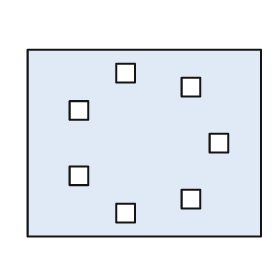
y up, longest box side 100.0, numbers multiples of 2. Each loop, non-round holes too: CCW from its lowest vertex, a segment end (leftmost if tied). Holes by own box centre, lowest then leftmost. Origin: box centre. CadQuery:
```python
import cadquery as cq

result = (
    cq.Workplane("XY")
    .moveTo(-50.0, -40.0)
    .lineTo(50.0, -40.0)
    .lineTo(50.0, 40.0)
    .lineTo(-50.0, 40.0)
    .close()
    .moveTo(-12.0, -34.0)
    .lineTo(-4.0, -34.0)
    .lineTo(-4.0, -26.0)
    .lineTo(-12.0, -26.0)
    .close()
    .moveTo(16.0, -28.0)
    .lineTo(24.0, -28.0)
    .lineTo(24.0, -20.0)
    .lineTo(16.0, -20.0)
    .close()
    .moveTo(-32.0, -18.0)
    .lineTo(-24.0, -18.0)
    .lineTo(-24.0, -10.0)
    .lineTo(-32.0, -10.0)
    .close()
    .moveTo(28.0, -4.0)
    .lineTo(36.0, -4.0)
    .lineTo(36.0, 4.0)
    .lineTo(28.0, 4.0)
    .close()
    .moveTo(-32.0, 10.0)
    .lineTo(-24.0, 10.0)
    .lineTo(-24.0, 18.0)
    .lineTo(-32.0, 18.0)
    .close()
    .moveTo(16.0, 20.0)
    .lineTo(24.0, 20.0)
    .lineTo(24.0, 28.0)
    .lineTo(16.0, 28.0)
    .close()
    .moveTo(-12.0, 26.0)
    .lineTo(-4.0, 26.0)
    .lineTo(-4.0, 34.0)
    .lineTo(-12.0, 34.0)
    .close()
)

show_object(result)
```